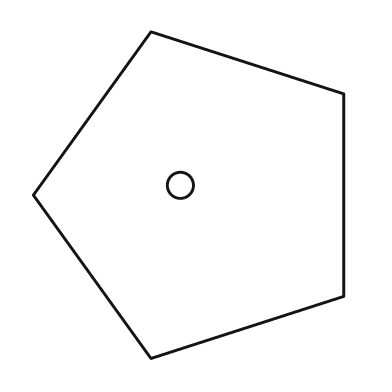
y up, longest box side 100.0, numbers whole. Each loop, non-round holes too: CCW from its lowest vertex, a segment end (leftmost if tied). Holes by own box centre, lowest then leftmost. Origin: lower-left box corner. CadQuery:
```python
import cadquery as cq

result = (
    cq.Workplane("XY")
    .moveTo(36.0, 0.0)
    .lineTo(95.0, 19.0)
    .lineTo(95.0, 81.0)
    .lineTo(36.0, 100.0)
    .lineTo(0.0, 50.0)
    .close()
    .moveTo(45.0, 53.0)
    .circle(4.0)
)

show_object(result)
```